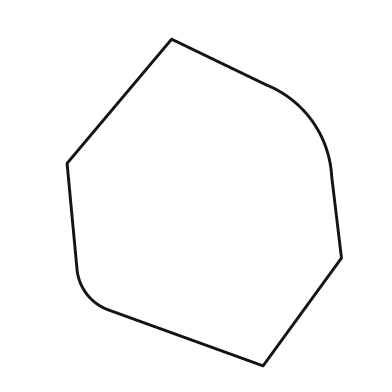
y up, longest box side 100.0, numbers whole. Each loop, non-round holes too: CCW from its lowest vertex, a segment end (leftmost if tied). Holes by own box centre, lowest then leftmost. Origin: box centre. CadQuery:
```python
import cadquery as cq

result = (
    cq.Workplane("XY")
    .moveTo(18.0, -50.0)
    .lineTo(42.0, -17.0)
    .lineTo(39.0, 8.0)
    .threePointArc((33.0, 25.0), (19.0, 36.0))
    .lineTo(-10.0, 50.0)
    .lineTo(-42.0, 12.0)
    .lineTo(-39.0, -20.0)
    .threePointArc((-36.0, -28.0), (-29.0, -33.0))
    .close()
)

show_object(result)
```